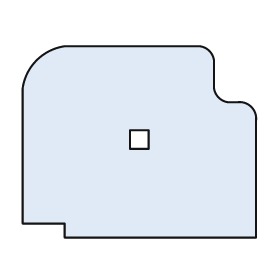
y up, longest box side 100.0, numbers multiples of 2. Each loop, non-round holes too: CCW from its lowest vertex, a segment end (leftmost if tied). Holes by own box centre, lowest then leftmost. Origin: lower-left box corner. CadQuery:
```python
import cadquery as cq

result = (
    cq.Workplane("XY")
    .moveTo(18.0, 0.0)
    .lineTo(100.0, 0.0)
    .lineTo(100.0, 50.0)
    .threePointArc((98.0, 56.0), (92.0, 58.0))
    .lineTo(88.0, 58.0)
    .threePointArc((84.0, 60.0), (82.0, 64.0))
    .lineTo(82.0, 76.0)
    .threePointArc((80.0, 80.0), (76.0, 82.0))
    .lineTo(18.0, 82.0)
    .threePointArc((6.0, 76.0), (0.0, 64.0))
    .lineTo(0.0, 6.0)
    .lineTo(18.0, 6.0)
    .close()
    .moveTo(46.0, 38.0)
    .lineTo(54.0, 38.0)
    .lineTo(54.0, 46.0)
    .lineTo(46.0, 46.0)
    .close()
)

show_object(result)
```